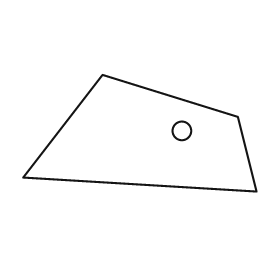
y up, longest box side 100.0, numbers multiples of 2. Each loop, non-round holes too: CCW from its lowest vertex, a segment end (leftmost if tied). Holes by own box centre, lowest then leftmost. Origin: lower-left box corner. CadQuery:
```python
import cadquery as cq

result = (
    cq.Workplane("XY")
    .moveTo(100.0, 0.0)
    .lineTo(92.0, 32.0)
    .lineTo(34.0, 50.0)
    .lineTo(0.0, 6.0)
    .close()
    .moveTo(68.0, 26.0)
    .circle(4.0)
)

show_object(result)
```